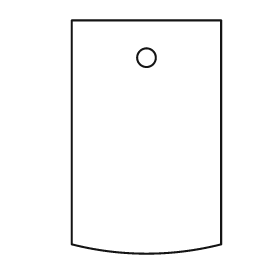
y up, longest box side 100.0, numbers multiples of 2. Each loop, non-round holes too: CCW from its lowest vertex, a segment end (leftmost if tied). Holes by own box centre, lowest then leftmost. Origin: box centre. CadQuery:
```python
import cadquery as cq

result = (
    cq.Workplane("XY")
    .moveTo(-32.0, -46.0)
    .threePointArc((0.0, -50.0), (32.0, -46.0))
    .lineTo(32.0, 50.0)
    .lineTo(-32.0, 50.0)
    .close()
    .moveTo(0.0, 34.0)
    .circle(4.0)
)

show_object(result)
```